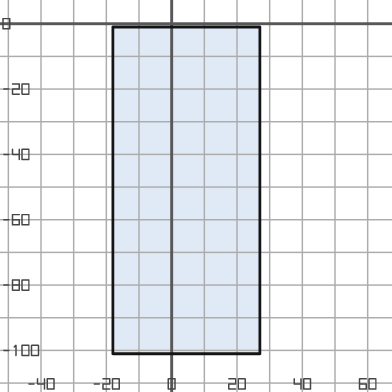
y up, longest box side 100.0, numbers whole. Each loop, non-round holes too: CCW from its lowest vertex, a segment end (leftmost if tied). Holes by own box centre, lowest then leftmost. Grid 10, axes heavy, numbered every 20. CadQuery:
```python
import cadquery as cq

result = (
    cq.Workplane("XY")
    .moveTo(-18.0, -101.0)
    .lineTo(27.0, -101.0)
    .lineTo(27.0, -1.0)
    .lineTo(-18.0, -1.0)
    .close()
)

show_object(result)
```